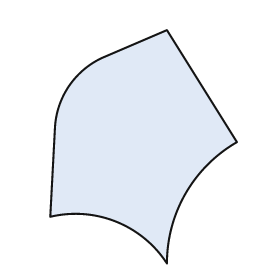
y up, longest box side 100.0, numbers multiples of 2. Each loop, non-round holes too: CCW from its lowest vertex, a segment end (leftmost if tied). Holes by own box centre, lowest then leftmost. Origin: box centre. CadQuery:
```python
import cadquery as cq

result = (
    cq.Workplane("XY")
    .moveTo(10.0, -50.0)
    .threePointArc((18.0, -20.0), (40.0, 2.0))
    .lineTo(10.0, 50.0)
    .lineTo(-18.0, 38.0)
    .threePointArc((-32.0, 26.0), (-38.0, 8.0))
    .lineTo(-40.0, -30.0)
    .threePointArc((-12.0, -32.0), (10.0, -50.0))
    .close()
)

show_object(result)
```